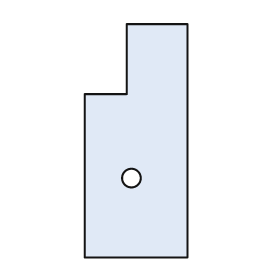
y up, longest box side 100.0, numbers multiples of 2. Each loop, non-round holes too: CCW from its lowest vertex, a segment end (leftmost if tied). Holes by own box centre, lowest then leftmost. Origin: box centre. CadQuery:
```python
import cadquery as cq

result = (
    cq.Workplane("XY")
    .moveTo(-22.0, -50.0)
    .lineTo(22.0, -50.0)
    .lineTo(22.0, 50.0)
    .lineTo(-4.0, 50.0)
    .lineTo(-4.0, 20.0)
    .lineTo(-22.0, 20.0)
    .close()
    .moveTo(-2.0, -16.0)
    .circle(4.0)
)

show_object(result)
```